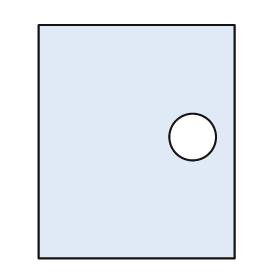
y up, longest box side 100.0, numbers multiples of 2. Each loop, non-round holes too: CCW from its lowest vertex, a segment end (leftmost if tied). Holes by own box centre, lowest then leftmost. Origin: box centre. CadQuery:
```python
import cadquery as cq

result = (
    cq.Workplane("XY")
    .moveTo(-42.0, -50.0)
    .lineTo(42.0, -50.0)
    .lineTo(42.0, 50.0)
    .lineTo(-42.0, 50.0)
    .close()
    .moveTo(24.0, 2.0)
    .circle(10.0)
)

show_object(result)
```